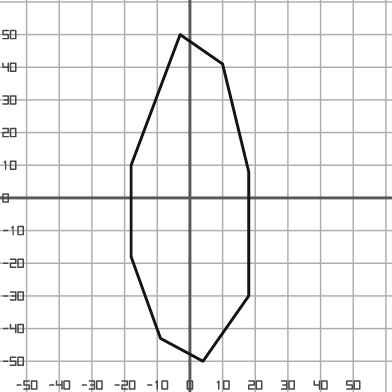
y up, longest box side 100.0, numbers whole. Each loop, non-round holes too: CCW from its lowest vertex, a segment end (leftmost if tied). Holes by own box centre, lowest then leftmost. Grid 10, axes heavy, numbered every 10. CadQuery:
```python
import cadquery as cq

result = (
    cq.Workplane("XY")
    .moveTo(4.0, -50.0)
    .lineTo(18.0, -30.0)
    .lineTo(18.0, 8.0)
    .lineTo(10.0, 41.0)
    .lineTo(-3.0, 50.0)
    .lineTo(-18.0, 10.0)
    .lineTo(-18.0, -18.0)
    .lineTo(-9.0, -43.0)
    .close()
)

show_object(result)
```